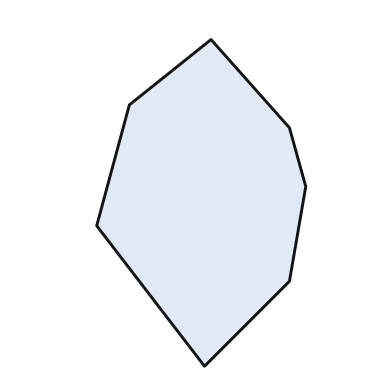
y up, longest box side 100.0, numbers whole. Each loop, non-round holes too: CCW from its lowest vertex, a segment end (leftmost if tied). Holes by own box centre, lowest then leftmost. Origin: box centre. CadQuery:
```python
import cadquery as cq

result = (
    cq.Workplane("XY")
    .moveTo(1.0, -50.0)
    .lineTo(27.0, -24.0)
    .lineTo(32.0, 5.0)
    .lineTo(27.0, 23.0)
    .lineTo(3.0, 50.0)
    .lineTo(-22.0, 30.0)
    .lineTo(-32.0, -7.0)
    .close()
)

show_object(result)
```